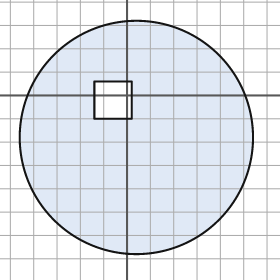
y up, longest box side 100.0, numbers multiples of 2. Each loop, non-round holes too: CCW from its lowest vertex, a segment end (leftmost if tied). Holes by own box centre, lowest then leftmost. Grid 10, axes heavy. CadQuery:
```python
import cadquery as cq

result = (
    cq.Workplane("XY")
    .moveTo(4.0, -18.0)
    .circle(50.0)
    .moveTo(-14.0, -10.0)
    .lineTo(2.0, -10.0)
    .lineTo(2.0, 6.0)
    .lineTo(-14.0, 6.0)
    .close()
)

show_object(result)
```